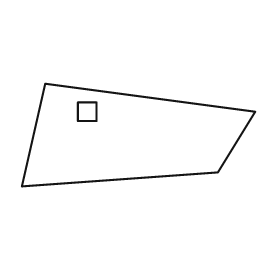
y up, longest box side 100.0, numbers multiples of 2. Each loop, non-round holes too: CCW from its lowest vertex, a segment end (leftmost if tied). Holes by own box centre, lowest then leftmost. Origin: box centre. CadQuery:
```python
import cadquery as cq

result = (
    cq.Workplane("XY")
    .moveTo(-50.0, -22.0)
    .lineTo(34.0, -16.0)
    .lineTo(50.0, 10.0)
    .lineTo(-40.0, 22.0)
    .close()
    .moveTo(-26.0, 6.0)
    .lineTo(-18.0, 6.0)
    .lineTo(-18.0, 14.0)
    .lineTo(-26.0, 14.0)
    .close()
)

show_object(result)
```